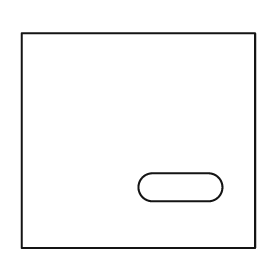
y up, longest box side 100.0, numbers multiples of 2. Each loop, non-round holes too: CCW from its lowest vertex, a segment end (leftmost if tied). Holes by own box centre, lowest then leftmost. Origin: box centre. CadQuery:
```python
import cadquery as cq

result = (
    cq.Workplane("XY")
    .moveTo(-50.0, -46.0)
    .lineTo(50.0, -46.0)
    .lineTo(50.0, 46.0)
    .lineTo(-50.0, 46.0)
    .close()
    .moveTo(6.0, -26.0)
    .lineTo(30.0, -26.0)
    .threePointArc((36.0, -20.0), (30.0, -14.0))
    .lineTo(6.0, -14.0)
    .threePointArc((0.0, -20.0), (6.0, -26.0))
    .close()
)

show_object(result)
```